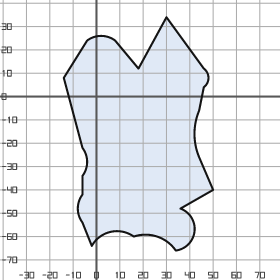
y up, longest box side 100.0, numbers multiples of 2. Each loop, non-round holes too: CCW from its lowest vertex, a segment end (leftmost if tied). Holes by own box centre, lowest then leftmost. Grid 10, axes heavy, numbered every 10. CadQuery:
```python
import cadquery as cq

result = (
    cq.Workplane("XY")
    .moveTo(34.0, -66.0)
    .threePointArc((42.0, -58.0), (36.0, -48.0))
    .lineTo(50.0, -40.0)
    .lineTo(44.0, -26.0)
    .threePointArc((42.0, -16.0), (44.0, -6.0))
    .lineTo(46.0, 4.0)
    .threePointArc((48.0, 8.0), (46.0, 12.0))
    .lineTo(30.0, 34.0)
    .lineTo(18.0, 12.0)
    .lineTo(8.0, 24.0)
    .threePointArc((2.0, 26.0), (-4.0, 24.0))
    .lineTo(-14.0, 8.0)
    .lineTo(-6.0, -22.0)
    .threePointArc((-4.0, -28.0), (-6.0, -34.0))
    .lineTo(-6.0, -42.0)
    .threePointArc((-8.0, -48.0), (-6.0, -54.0))
    .lineTo(-2.0, -64.0)
    .threePointArc((6.0, -58.0), (16.0, -60.0))
    .threePointArc((26.0, -60.0), (34.0, -66.0))
    .close()
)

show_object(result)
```